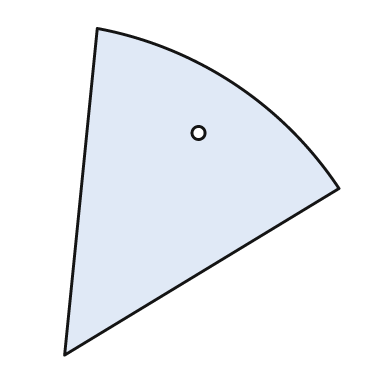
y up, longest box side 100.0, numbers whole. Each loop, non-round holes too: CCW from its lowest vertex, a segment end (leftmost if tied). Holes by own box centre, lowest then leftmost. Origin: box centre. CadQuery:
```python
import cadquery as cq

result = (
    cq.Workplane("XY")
    .moveTo(-42.0, -50.0)
    .lineTo(42.0, 1.0)
    .threePointArc((10.0, 33.0), (-32.0, 50.0))
    .close()
    .moveTo(-1.0, 18.0)
    .circle(2.0)
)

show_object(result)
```